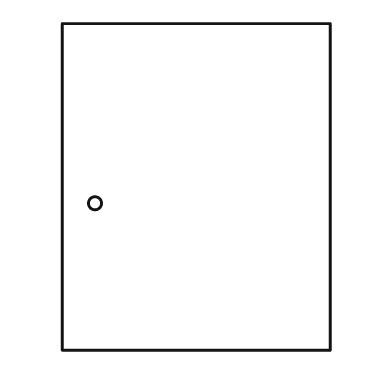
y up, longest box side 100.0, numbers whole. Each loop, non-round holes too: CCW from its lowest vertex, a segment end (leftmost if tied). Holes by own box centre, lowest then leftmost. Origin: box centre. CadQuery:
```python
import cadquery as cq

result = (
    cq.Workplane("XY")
    .moveTo(-41.0, -50.0)
    .lineTo(41.0, -50.0)
    .lineTo(41.0, 50.0)
    .lineTo(-41.0, 50.0)
    .close()
    .moveTo(-31.0, -5.0)
    .circle(2.0)
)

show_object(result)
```